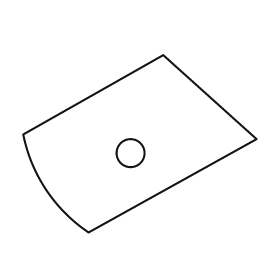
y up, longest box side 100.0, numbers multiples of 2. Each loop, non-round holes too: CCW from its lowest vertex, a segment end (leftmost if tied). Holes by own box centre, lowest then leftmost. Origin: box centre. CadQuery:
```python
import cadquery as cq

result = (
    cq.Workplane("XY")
    .moveTo(-22.0, -38.0)
    .lineTo(50.0, 2.0)
    .lineTo(10.0, 38.0)
    .lineTo(-50.0, 4.0)
    .threePointArc((-40.0, -20.0), (-22.0, -38.0))
    .close()
    .moveTo(-4.0, -4.0)
    .circle(6.0)
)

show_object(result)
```